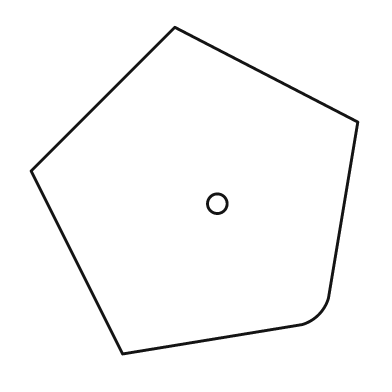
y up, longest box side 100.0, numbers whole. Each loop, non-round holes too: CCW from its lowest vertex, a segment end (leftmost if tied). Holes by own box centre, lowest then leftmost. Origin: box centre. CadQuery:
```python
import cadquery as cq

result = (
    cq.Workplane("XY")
    .moveTo(-22.0, -50.0)
    .lineTo(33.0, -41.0)
    .threePointArc((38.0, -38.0), (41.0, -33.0))
    .lineTo(50.0, 21.0)
    .lineTo(-6.0, 50.0)
    .lineTo(-50.0, 6.0)
    .close()
    .moveTo(7.0, -4.0)
    .circle(3.0)
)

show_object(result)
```